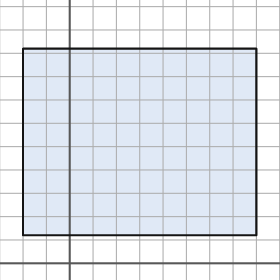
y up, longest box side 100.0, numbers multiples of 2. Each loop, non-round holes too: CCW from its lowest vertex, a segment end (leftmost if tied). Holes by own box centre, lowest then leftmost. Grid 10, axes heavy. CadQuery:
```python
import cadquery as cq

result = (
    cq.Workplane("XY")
    .moveTo(-20.0, 12.0)
    .lineTo(80.0, 12.0)
    .lineTo(80.0, 92.0)
    .lineTo(-20.0, 92.0)
    .close()
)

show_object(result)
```